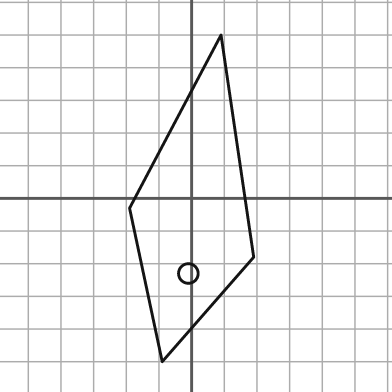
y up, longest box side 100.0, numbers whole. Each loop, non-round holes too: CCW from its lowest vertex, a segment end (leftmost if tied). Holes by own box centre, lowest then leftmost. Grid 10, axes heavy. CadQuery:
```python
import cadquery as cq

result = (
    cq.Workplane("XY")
    .moveTo(-9.0, -50.0)
    .lineTo(19.0, -18.0)
    .lineTo(9.0, 50.0)
    .lineTo(-19.0, -3.0)
    .close()
    .moveTo(-1.0, -23.0)
    .circle(3.0)
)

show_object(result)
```